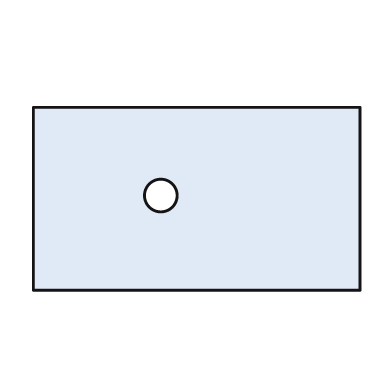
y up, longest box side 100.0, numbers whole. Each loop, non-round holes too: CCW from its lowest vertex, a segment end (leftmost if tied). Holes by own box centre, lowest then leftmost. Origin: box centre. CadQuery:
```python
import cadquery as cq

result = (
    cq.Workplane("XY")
    .moveTo(-50.0, -28.0)
    .lineTo(50.0, -28.0)
    .lineTo(50.0, 28.0)
    .lineTo(-50.0, 28.0)
    .close()
    .moveTo(-11.0, 1.0)
    .circle(5.0)
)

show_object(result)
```